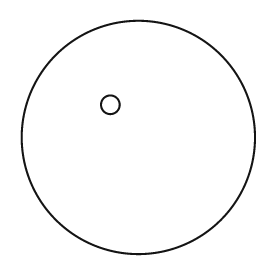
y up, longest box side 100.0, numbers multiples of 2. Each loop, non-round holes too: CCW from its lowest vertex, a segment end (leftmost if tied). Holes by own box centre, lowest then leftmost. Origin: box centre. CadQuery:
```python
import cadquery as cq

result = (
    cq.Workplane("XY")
    .moveTo(0.0, 0.0)
    .circle(50.0)
    .moveTo(-12.0, 14.0)
    .circle(4.0)
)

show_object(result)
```